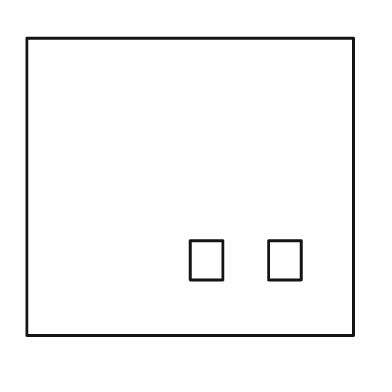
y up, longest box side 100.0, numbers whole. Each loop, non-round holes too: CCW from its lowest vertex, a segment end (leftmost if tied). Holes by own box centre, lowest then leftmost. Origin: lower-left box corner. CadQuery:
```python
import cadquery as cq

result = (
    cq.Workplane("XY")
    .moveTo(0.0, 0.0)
    .lineTo(100.0, 0.0)
    .lineTo(100.0, 91.0)
    .lineTo(0.0, 91.0)
    .close()
    .moveTo(50.0, 17.0)
    .lineTo(60.0, 17.0)
    .lineTo(60.0, 29.0)
    .lineTo(50.0, 29.0)
    .close()
    .moveTo(74.0, 17.0)
    .lineTo(84.0, 17.0)
    .lineTo(84.0, 29.0)
    .lineTo(74.0, 29.0)
    .close()
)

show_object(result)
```